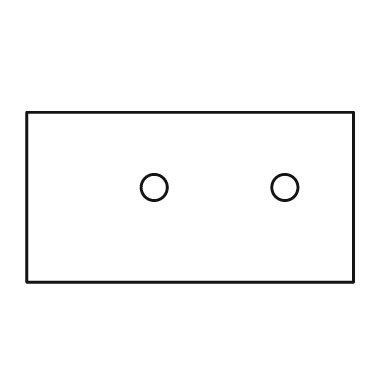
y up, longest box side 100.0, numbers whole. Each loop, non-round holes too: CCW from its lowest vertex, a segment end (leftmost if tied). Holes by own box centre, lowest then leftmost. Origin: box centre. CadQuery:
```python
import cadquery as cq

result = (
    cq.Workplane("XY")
    .moveTo(-50.0, -26.0)
    .lineTo(50.0, -26.0)
    .lineTo(50.0, 26.0)
    .lineTo(-50.0, 26.0)
    .close()
    .moveTo(-11.0, 3.0)
    .circle(4.0)
    .moveTo(29.0, 3.0)
    .circle(4.0)
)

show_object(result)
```